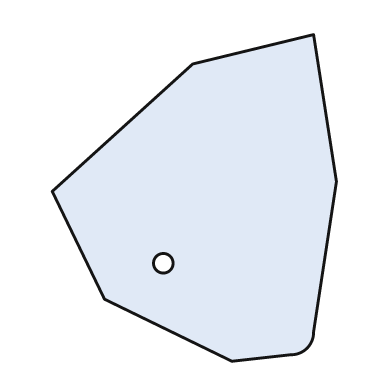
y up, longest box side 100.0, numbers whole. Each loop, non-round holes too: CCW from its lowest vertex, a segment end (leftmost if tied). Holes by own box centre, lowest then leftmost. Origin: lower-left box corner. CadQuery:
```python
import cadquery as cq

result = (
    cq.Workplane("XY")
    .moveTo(55.0, 0.0)
    .lineTo(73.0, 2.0)
    .threePointArc((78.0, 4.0), (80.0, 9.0))
    .lineTo(87.0, 55.0)
    .lineTo(80.0, 100.0)
    .lineTo(43.0, 91.0)
    .lineTo(0.0, 52.0)
    .lineTo(16.0, 19.0)
    .close()
    .moveTo(34.0, 30.0)
    .circle(3.0)
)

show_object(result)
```